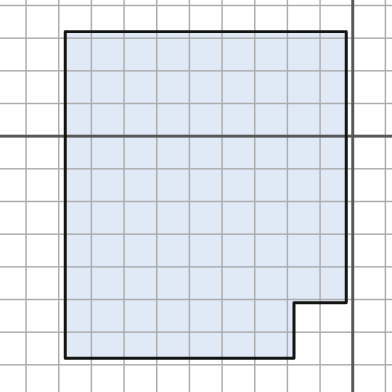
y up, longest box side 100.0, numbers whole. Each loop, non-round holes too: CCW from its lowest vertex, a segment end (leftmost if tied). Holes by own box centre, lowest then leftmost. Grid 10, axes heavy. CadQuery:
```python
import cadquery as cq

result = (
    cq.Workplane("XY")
    .moveTo(-88.0, -68.0)
    .lineTo(-18.0, -68.0)
    .lineTo(-18.0, -51.0)
    .lineTo(-2.0, -51.0)
    .lineTo(-2.0, 32.0)
    .lineTo(-88.0, 32.0)
    .close()
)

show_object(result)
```